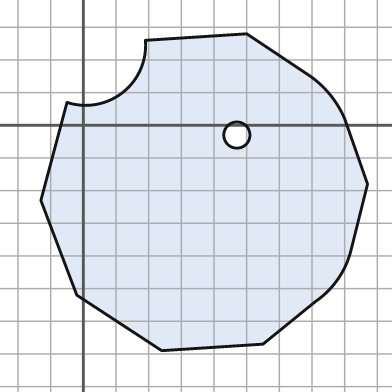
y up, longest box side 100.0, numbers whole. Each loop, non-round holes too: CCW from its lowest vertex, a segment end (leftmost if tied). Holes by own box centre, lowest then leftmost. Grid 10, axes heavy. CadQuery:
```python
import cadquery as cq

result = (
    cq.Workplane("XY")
    .moveTo(24.0, -69.0)
    .lineTo(55.0, -67.0)
    .lineTo(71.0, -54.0)
    .threePointArc((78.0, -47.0), (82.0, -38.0))
    .lineTo(87.0, -18.0)
    .lineTo(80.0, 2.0)
    .threePointArc((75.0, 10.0), (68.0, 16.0))
    .lineTo(50.0, 28.0)
    .lineTo(19.0, 26.0)
    .threePointArc((12.0, 10.0), (-5.0, 7.0))
    .lineTo(-13.0, -23.0)
    .lineTo(-2.0, -52.0)
    .close()
    .moveTo(47.0, -3.0)
    .circle(4.0)
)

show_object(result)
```